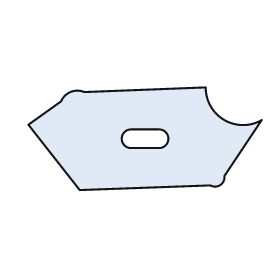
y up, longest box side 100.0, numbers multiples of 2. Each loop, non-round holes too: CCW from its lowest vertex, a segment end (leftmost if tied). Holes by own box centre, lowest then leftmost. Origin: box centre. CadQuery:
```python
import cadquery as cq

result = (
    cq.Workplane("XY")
    .moveTo(-28.0, -22.0)
    .lineTo(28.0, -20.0)
    .threePointArc((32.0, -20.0), (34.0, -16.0))
    .lineTo(50.0, 8.0)
    .threePointArc((34.0, 8.0), (26.0, 22.0))
    .lineTo(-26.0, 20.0)
    .threePointArc((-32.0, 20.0), (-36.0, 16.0))
    .lineTo(-50.0, 6.0)
    .close()
    .moveTo(-6.0, -4.0)
    .lineTo(6.0, -4.0)
    .threePointArc((10.0, 0.0), (6.0, 4.0))
    .lineTo(-6.0, 4.0)
    .threePointArc((-10.0, 0.0), (-6.0, -4.0))
    .close()
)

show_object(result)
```